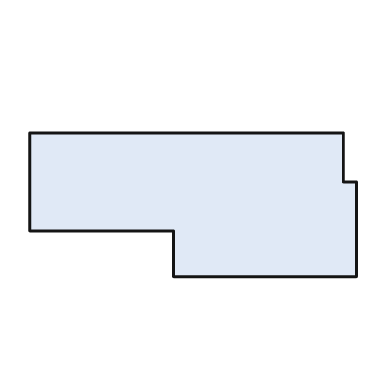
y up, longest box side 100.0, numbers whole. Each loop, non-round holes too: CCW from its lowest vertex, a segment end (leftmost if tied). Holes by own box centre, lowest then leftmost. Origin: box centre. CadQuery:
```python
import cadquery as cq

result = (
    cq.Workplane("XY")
    .moveTo(-6.0, -22.0)
    .lineTo(50.0, -22.0)
    .lineTo(50.0, 7.0)
    .lineTo(46.0, 7.0)
    .lineTo(46.0, 22.0)
    .lineTo(-50.0, 22.0)
    .lineTo(-50.0, -8.0)
    .lineTo(-6.0, -8.0)
    .close()
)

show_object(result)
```